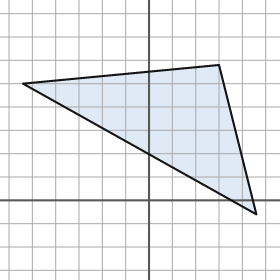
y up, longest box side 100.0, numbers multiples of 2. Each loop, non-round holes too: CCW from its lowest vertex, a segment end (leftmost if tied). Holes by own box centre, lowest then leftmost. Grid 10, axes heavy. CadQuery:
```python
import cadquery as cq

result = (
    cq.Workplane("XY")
    .moveTo(46.0, -6.0)
    .lineTo(30.0, 58.0)
    .lineTo(-54.0, 50.0)
    .close()
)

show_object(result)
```